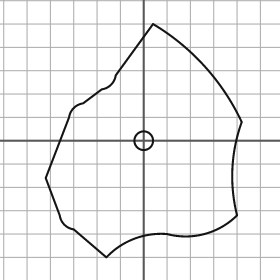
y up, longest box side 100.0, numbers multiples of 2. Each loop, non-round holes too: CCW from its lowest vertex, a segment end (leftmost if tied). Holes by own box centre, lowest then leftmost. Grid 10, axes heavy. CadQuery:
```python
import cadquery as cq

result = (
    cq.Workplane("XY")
    .moveTo(-16.0, -50.0)
    .threePointArc((-4.0, -42.0), (10.0, -40.0))
    .threePointArc((26.0, -40.0), (40.0, -32.0))
    .threePointArc((38.0, -12.0), (42.0, 8.0))
    .threePointArc((26.0, 32.0), (4.0, 50.0))
    .lineTo(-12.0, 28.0)
    .threePointArc((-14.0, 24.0), (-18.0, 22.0))
    .lineTo(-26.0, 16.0)
    .threePointArc((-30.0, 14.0), (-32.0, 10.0))
    .lineTo(-42.0, -16.0)
    .lineTo(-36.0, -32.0)
    .threePointArc((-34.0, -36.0), (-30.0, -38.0))
    .close()
    .moveTo(0.0, 0.0)
    .circle(4.0)
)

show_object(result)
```